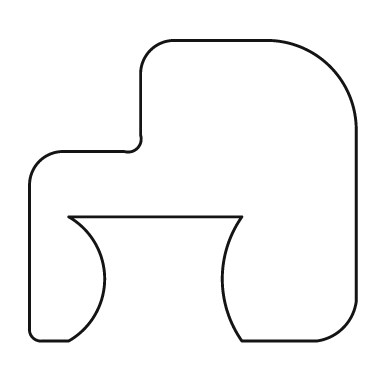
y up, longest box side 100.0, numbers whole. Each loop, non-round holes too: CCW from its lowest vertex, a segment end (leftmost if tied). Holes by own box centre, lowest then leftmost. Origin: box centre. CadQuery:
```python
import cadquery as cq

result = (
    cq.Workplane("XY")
    .moveTo(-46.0, -46.0)
    .lineTo(-38.0, -46.0)
    .threePointArc((-27.0, -27.0), (-38.0, -8.0))
    .lineTo(15.0, -8.0)
    .threePointArc((9.0, -27.0), (15.0, -46.0))
    .lineTo(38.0, -46.0)
    .threePointArc((46.0, -42.0), (50.0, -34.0))
    .lineTo(50.0, 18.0)
    .threePointArc((42.0, 38.0), (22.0, 46.0))
    .lineTo(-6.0, 46.0)
    .threePointArc((-13.0, 43.0), (-16.0, 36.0))
    .lineTo(-16.0, 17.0)
    .threePointArc((-17.0, 13.0), (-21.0, 12.0))
    .lineTo(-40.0, 12.0)
    .threePointArc((-47.0, 9.0), (-50.0, 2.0))
    .lineTo(-50.0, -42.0)
    .threePointArc((-49.0, -45.0), (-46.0, -46.0))
    .close()
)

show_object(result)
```